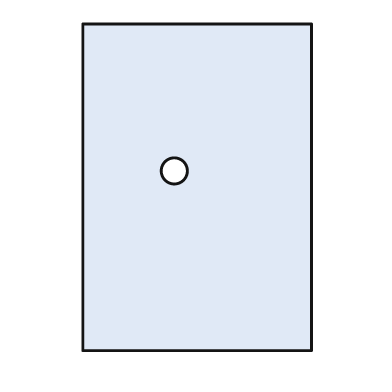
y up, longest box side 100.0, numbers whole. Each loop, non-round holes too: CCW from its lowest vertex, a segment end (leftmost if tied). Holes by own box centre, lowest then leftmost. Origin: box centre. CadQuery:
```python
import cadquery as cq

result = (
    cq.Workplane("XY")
    .moveTo(-35.0, -50.0)
    .lineTo(35.0, -50.0)
    .lineTo(35.0, 50.0)
    .lineTo(-35.0, 50.0)
    .close()
    .moveTo(-7.0, 5.0)
    .circle(4.0)
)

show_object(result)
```